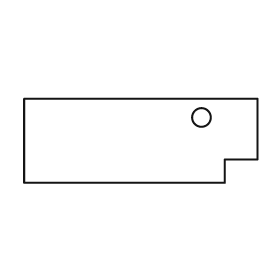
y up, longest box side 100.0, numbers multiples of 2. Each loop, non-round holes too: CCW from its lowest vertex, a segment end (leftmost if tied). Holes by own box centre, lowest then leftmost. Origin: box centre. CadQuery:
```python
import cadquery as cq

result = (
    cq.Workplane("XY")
    .moveTo(-50.0, -18.0)
    .lineTo(36.0, -18.0)
    .lineTo(36.0, -8.0)
    .lineTo(50.0, -8.0)
    .lineTo(50.0, 18.0)
    .lineTo(-50.0, 18.0)
    .close()
    .moveTo(26.0, 10.0)
    .circle(4.0)
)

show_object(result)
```